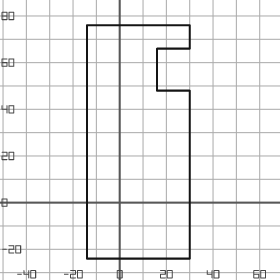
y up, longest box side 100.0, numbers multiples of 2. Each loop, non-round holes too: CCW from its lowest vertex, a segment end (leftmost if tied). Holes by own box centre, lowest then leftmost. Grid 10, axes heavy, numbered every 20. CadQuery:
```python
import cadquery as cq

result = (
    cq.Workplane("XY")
    .moveTo(-14.0, -24.0)
    .lineTo(30.0, -24.0)
    .lineTo(30.0, 48.0)
    .lineTo(16.0, 48.0)
    .lineTo(16.0, 66.0)
    .lineTo(30.0, 66.0)
    .lineTo(30.0, 76.0)
    .lineTo(-14.0, 76.0)
    .close()
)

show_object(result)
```